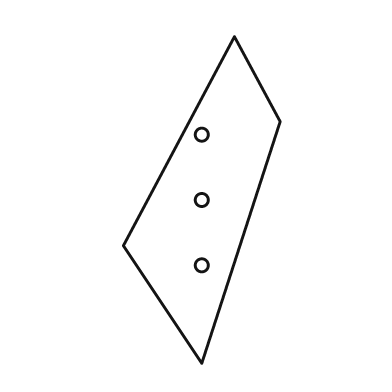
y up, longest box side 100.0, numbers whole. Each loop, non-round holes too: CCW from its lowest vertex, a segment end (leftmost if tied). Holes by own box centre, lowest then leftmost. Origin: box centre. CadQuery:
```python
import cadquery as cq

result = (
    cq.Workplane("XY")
    .moveTo(0.0, -50.0)
    .lineTo(24.0, 24.0)
    .lineTo(10.0, 50.0)
    .lineTo(-24.0, -14.0)
    .close()
    .moveTo(0.0, -20.0)
    .circle(2.0)
    .moveTo(0.0, 0.0)
    .circle(2.0)
    .moveTo(0.0, 20.0)
    .circle(2.0)
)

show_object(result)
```